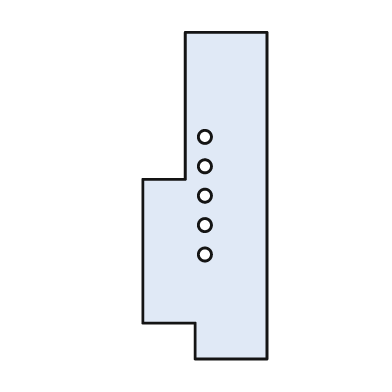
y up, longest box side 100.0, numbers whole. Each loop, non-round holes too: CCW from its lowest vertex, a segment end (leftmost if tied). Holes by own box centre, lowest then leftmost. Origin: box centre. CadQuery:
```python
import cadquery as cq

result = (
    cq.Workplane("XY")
    .moveTo(-3.0, -50.0)
    .lineTo(19.0, -50.0)
    .lineTo(19.0, 50.0)
    .lineTo(-6.0, 50.0)
    .lineTo(-6.0, 5.0)
    .lineTo(-19.0, 5.0)
    .lineTo(-19.0, -39.0)
    .lineTo(-3.0, -39.0)
    .close()
    .moveTo(0.0, -18.0)
    .circle(2.0)
    .moveTo(0.0, -9.0)
    .circle(2.0)
    .moveTo(0.0, 0.0)
    .circle(2.0)
    .moveTo(0.0, 9.0)
    .circle(2.0)
    .moveTo(0.0, 18.0)
    .circle(2.0)
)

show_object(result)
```